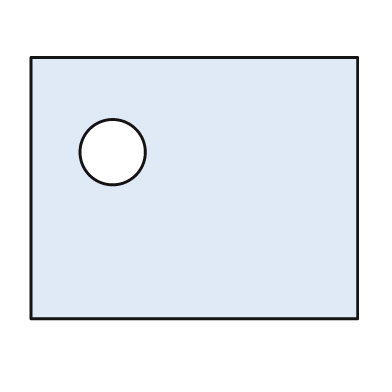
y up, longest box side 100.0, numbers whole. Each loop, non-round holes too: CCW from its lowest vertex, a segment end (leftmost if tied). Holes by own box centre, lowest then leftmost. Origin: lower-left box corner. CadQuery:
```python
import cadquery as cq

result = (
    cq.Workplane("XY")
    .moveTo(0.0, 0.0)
    .lineTo(100.0, 0.0)
    .lineTo(100.0, 80.0)
    .lineTo(0.0, 80.0)
    .close()
    .moveTo(25.0, 51.0)
    .circle(10.0)
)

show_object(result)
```